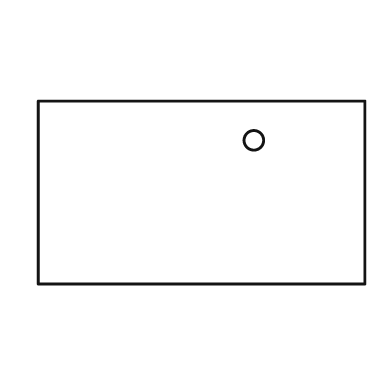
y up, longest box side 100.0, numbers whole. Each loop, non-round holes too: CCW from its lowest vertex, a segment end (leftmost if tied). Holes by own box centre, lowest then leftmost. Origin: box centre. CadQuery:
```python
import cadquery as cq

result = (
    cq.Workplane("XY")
    .moveTo(-50.0, -28.0)
    .lineTo(50.0, -28.0)
    .lineTo(50.0, 28.0)
    .lineTo(-50.0, 28.0)
    .close()
    .moveTo(16.0, 16.0)
    .circle(3.0)
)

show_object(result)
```